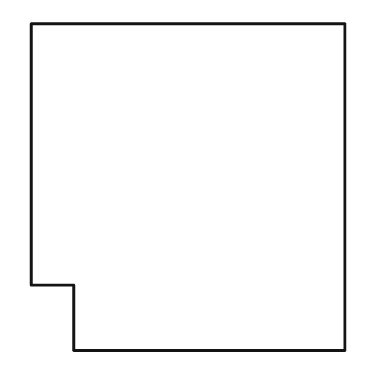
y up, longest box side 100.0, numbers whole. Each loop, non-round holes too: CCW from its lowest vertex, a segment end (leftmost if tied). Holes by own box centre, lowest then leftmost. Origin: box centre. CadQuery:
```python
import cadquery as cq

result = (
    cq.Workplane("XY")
    .moveTo(-35.0, -50.0)
    .lineTo(48.0, -50.0)
    .lineTo(48.0, 50.0)
    .lineTo(-48.0, 50.0)
    .lineTo(-48.0, -30.0)
    .lineTo(-35.0, -30.0)
    .close()
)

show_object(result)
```